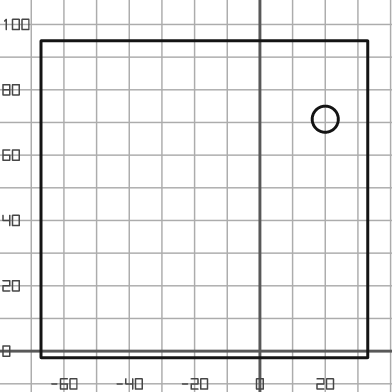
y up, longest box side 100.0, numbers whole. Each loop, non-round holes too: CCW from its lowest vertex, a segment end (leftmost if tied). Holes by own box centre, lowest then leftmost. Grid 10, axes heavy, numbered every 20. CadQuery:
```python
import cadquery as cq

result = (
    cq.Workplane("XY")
    .moveTo(-67.0, -2.0)
    .lineTo(33.0, -2.0)
    .lineTo(33.0, 95.0)
    .lineTo(-67.0, 95.0)
    .close()
    .moveTo(20.0, 71.0)
    .circle(4.0)
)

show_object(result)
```